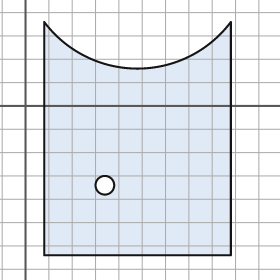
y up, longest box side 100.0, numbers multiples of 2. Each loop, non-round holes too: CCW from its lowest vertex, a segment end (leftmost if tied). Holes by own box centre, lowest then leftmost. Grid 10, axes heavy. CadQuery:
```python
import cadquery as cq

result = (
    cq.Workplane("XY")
    .moveTo(8.0, -64.0)
    .lineTo(88.0, -64.0)
    .lineTo(88.0, 36.0)
    .threePointArc((48.0, 16.0), (8.0, 36.0))
    .close()
    .moveTo(34.0, -34.0)
    .circle(4.0)
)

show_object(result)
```